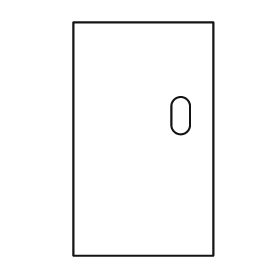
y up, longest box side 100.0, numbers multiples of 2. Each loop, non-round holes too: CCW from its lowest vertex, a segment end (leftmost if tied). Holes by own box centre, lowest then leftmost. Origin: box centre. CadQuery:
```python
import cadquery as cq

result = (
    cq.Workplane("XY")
    .moveTo(-30.0, -50.0)
    .lineTo(30.0, -50.0)
    .lineTo(30.0, 50.0)
    .lineTo(-30.0, 50.0)
    .close()
    .moveTo(12.0, 6.0)
    .threePointArc((16.0, 2.0), (20.0, 6.0))
    .lineTo(20.0, 14.0)
    .threePointArc((16.0, 18.0), (12.0, 14.0))
    .close()
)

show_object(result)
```